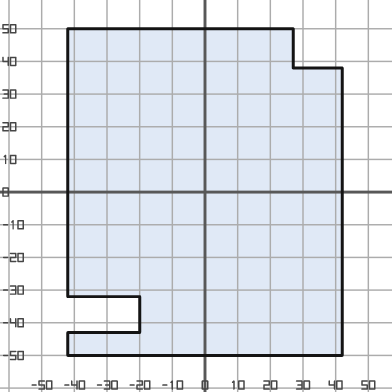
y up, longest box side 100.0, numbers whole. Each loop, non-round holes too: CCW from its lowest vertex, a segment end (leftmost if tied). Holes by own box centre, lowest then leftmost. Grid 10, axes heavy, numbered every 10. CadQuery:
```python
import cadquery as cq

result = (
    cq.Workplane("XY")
    .moveTo(-42.0, -50.0)
    .lineTo(42.0, -50.0)
    .lineTo(42.0, 38.0)
    .lineTo(27.0, 38.0)
    .lineTo(27.0, 50.0)
    .lineTo(-42.0, 50.0)
    .lineTo(-42.0, -32.0)
    .lineTo(-20.0, -32.0)
    .lineTo(-20.0, -43.0)
    .lineTo(-42.0, -43.0)
    .close()
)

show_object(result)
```